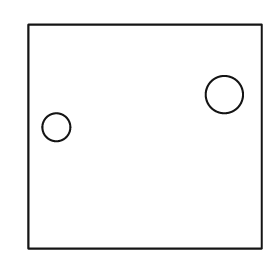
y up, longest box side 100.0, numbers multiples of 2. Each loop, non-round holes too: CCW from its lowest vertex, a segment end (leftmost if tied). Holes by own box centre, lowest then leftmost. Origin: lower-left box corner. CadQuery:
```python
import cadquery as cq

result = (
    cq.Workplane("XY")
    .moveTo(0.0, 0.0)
    .lineTo(100.0, 0.0)
    .lineTo(100.0, 96.0)
    .lineTo(0.0, 96.0)
    .close()
    .moveTo(12.0, 52.0)
    .circle(6.0)
    .moveTo(84.0, 66.0)
    .circle(8.0)
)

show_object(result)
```